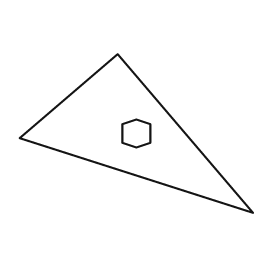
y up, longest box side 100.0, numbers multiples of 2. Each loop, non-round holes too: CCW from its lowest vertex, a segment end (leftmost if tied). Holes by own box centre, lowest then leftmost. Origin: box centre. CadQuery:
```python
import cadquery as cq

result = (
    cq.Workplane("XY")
    .moveTo(50.0, -34.0)
    .lineTo(-8.0, 34.0)
    .lineTo(-50.0, -2.0)
    .close()
    .moveTo(0.0, -6.0)
    .lineTo(6.0, -4.0)
    .lineTo(6.0, 4.0)
    .lineTo(0.0, 6.0)
    .lineTo(-6.0, 4.0)
    .lineTo(-6.0, -4.0)
    .close()
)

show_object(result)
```